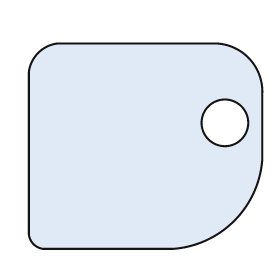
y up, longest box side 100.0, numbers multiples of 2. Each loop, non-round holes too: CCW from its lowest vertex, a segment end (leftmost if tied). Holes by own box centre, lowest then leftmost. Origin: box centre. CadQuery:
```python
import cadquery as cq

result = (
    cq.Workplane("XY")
    .moveTo(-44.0, -44.0)
    .lineTo(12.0, -44.0)
    .threePointArc((38.0, -32.0), (50.0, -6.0))
    .lineTo(50.0, 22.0)
    .threePointArc((44.0, 38.0), (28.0, 44.0))
    .lineTo(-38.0, 44.0)
    .threePointArc((-46.0, 40.0), (-50.0, 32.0))
    .lineTo(-50.0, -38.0)
    .threePointArc((-48.0, -42.0), (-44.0, -44.0))
    .close()
    .moveTo(34.0, 10.0)
    .circle(10.0)
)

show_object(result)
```